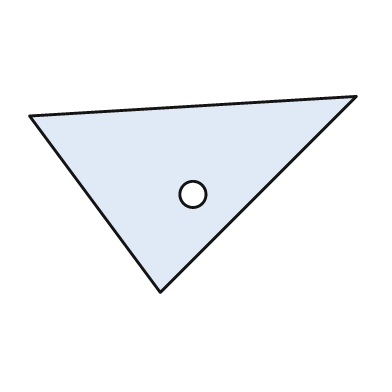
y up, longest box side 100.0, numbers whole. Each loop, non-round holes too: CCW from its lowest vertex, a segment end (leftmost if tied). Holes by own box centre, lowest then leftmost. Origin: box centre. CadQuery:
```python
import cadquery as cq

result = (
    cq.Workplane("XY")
    .moveTo(-10.0, -30.0)
    .lineTo(50.0, 30.0)
    .lineTo(-50.0, 24.0)
    .close()
    .moveTo(0.0, 0.0)
    .circle(4.0)
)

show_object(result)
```